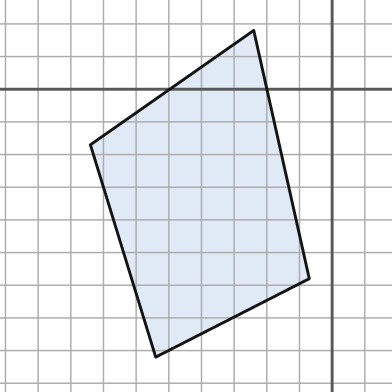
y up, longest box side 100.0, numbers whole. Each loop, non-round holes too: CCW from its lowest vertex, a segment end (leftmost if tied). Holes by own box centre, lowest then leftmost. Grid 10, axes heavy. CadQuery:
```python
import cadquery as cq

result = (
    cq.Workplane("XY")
    .moveTo(-54.0, -82.0)
    .lineTo(-7.0, -58.0)
    .lineTo(-24.0, 18.0)
    .lineTo(-74.0, -17.0)
    .close()
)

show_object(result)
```